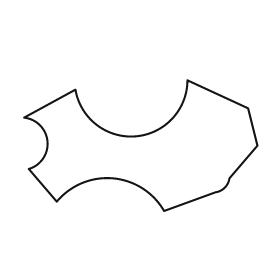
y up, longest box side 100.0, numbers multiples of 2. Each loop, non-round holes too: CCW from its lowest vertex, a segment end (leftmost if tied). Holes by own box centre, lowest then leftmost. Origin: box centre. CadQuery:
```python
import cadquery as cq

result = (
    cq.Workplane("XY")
    .moveTo(10.0, -28.0)
    .lineTo(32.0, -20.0)
    .threePointArc((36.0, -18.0), (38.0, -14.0))
    .lineTo(50.0, 0.0)
    .lineTo(46.0, 16.0)
    .lineTo(20.0, 28.0)
    .threePointArc((-2.0, 4.0), (-28.0, 24.0))
    .lineTo(-50.0, 12.0)
    .threePointArc((-40.0, 2.0), (-48.0, -10.0))
    .lineTo(-36.0, -24.0)
    .threePointArc((-12.0, -14.0), (10.0, -28.0))
    .close()
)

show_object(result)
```